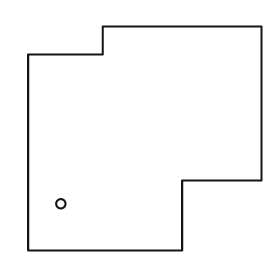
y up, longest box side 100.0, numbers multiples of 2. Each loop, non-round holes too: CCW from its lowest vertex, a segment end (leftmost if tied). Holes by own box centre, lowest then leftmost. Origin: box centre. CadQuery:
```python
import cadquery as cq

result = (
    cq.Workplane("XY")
    .moveTo(-50.0, -48.0)
    .lineTo(16.0, -48.0)
    .lineTo(16.0, -18.0)
    .lineTo(50.0, -18.0)
    .lineTo(50.0, 48.0)
    .lineTo(-18.0, 48.0)
    .lineTo(-18.0, 36.0)
    .lineTo(-50.0, 36.0)
    .close()
    .moveTo(-36.0, -28.0)
    .circle(2.0)
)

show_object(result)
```